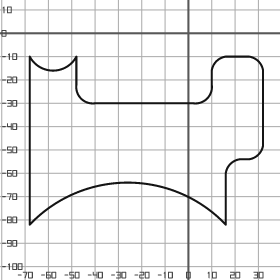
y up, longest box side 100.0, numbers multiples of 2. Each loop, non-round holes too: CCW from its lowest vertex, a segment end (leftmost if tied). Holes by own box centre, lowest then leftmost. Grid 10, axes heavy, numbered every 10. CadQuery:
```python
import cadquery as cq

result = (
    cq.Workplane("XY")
    .moveTo(-68.0, -82.0)
    .threePointArc((-26.0, -64.0), (16.0, -82.0))
    .lineTo(16.0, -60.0)
    .threePointArc((18.0, -56.0), (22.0, -54.0))
    .lineTo(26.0, -54.0)
    .threePointArc((30.0, -52.0), (32.0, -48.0))
    .lineTo(32.0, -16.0)
    .threePointArc((30.0, -12.0), (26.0, -10.0))
    .lineTo(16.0, -10.0)
    .threePointArc((12.0, -12.0), (10.0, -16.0))
    .lineTo(10.0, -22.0)
    .threePointArc((8.0, -28.0), (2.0, -30.0))
    .lineTo(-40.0, -30.0)
    .threePointArc((-46.0, -28.0), (-48.0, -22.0))
    .lineTo(-48.0, -10.0)
    .threePointArc((-58.0, -16.0), (-68.0, -10.0))
    .close()
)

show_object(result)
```